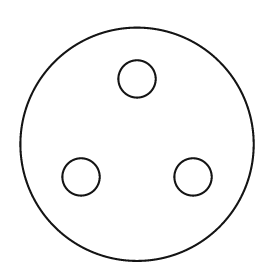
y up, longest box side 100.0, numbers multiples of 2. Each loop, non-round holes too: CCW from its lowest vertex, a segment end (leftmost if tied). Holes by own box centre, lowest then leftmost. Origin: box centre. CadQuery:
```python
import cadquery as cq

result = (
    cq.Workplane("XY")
    .moveTo(0.0, 0.0)
    .circle(50.0)
    .moveTo(-24.0, -14.0)
    .circle(8.0)
    .moveTo(24.0, -14.0)
    .circle(8.0)
    .moveTo(0.0, 28.0)
    .circle(8.0)
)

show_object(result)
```